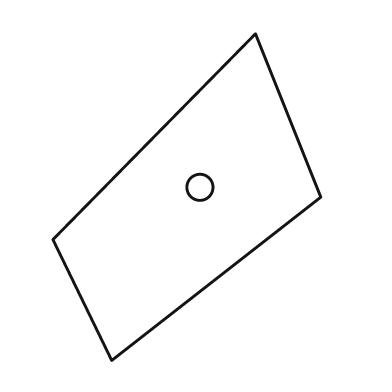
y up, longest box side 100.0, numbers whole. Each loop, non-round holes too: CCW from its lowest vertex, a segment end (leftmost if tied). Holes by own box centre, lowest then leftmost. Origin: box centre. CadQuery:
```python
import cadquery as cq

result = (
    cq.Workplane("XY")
    .moveTo(-23.0, -50.0)
    .lineTo(41.0, 0.0)
    .lineTo(21.0, 50.0)
    .lineTo(-41.0, -13.0)
    .close()
    .moveTo(4.0, 3.0)
    .circle(4.0)
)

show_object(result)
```